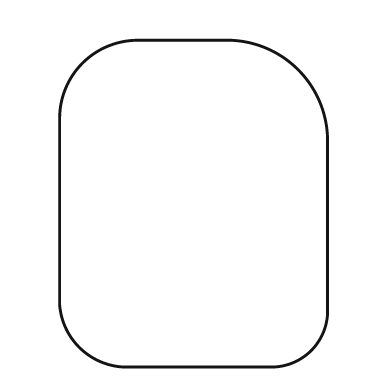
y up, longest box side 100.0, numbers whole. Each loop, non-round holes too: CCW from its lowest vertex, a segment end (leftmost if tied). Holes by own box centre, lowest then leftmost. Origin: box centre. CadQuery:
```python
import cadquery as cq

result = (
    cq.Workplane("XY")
    .moveTo(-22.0, -50.0)
    .lineTo(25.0, -50.0)
    .threePointArc((36.0, -45.0), (41.0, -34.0))
    .lineTo(41.0, 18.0)
    .threePointArc((32.0, 41.0), (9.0, 50.0))
    .lineTo(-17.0, 50.0)
    .threePointArc((-34.0, 43.0), (-41.0, 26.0))
    .lineTo(-41.0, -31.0)
    .threePointArc((-35.0, -44.0), (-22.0, -50.0))
    .close()
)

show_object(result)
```